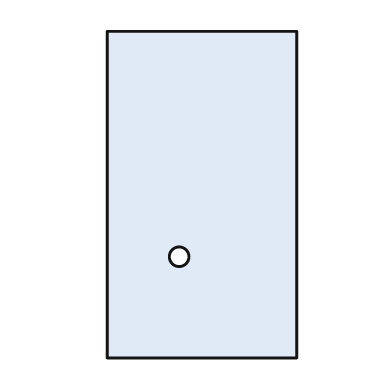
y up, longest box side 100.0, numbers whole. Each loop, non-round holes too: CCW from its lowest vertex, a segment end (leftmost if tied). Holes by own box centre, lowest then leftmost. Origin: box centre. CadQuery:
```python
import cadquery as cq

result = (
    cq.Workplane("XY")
    .moveTo(-29.0, -50.0)
    .lineTo(29.0, -50.0)
    .lineTo(29.0, 50.0)
    .lineTo(-29.0, 50.0)
    .close()
    .moveTo(-7.0, -19.0)
    .circle(3.0)
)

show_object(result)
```